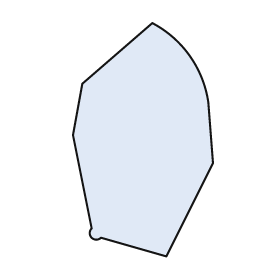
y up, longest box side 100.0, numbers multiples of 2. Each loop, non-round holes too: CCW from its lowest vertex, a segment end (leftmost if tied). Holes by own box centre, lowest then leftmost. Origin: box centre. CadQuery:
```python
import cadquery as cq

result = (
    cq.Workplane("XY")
    .moveTo(10.0, -50.0)
    .lineTo(30.0, -10.0)
    .lineTo(28.0, 16.0)
    .threePointArc((20.0, 36.0), (4.0, 50.0))
    .lineTo(-26.0, 24.0)
    .lineTo(-30.0, 2.0)
    .lineTo(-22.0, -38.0)
    .threePointArc((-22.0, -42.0), (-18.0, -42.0))
    .close()
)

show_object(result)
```